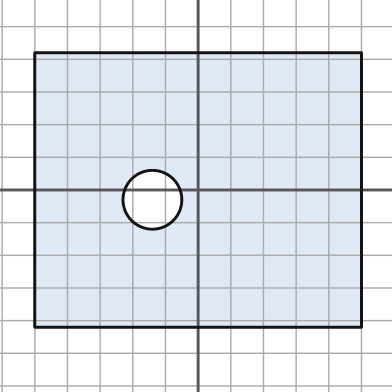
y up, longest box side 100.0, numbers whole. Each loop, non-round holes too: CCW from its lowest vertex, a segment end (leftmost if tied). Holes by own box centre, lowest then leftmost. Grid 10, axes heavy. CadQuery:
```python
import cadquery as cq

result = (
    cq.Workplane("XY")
    .moveTo(-50.0, -42.0)
    .lineTo(50.0, -42.0)
    .lineTo(50.0, 42.0)
    .lineTo(-50.0, 42.0)
    .close()
    .moveTo(-14.0, -3.0)
    .circle(9.0)
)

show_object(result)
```